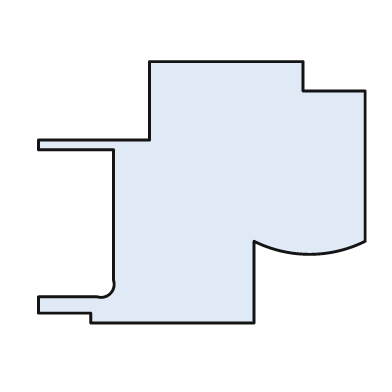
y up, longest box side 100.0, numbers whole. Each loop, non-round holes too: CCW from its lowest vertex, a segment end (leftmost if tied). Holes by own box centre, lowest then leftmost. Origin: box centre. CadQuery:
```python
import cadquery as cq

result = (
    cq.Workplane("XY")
    .moveTo(-34.0, -40.0)
    .lineTo(16.0, -40.0)
    .lineTo(16.0, -15.0)
    .threePointArc((33.0, -19.0), (50.0, -15.0))
    .lineTo(50.0, 31.0)
    .lineTo(31.0, 31.0)
    .lineTo(31.0, 40.0)
    .lineTo(-16.0, 40.0)
    .lineTo(-16.0, 16.0)
    .lineTo(-50.0, 16.0)
    .lineTo(-50.0, 13.0)
    .lineTo(-27.0, 13.0)
    .lineTo(-27.0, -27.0)
    .threePointArc((-28.0, -31.0), (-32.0, -32.0))
    .lineTo(-50.0, -32.0)
    .lineTo(-50.0, -37.0)
    .lineTo(-34.0, -37.0)
    .close()
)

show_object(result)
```